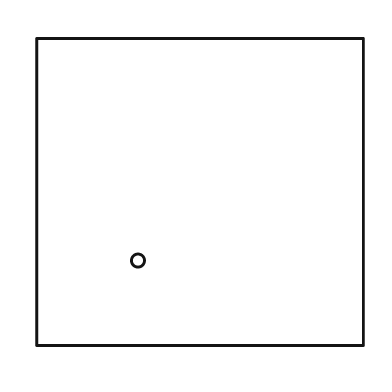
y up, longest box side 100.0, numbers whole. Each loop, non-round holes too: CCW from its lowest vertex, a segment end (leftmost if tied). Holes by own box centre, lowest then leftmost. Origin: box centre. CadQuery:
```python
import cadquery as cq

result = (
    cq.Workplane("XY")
    .moveTo(-50.0, -47.0)
    .lineTo(50.0, -47.0)
    .lineTo(50.0, 47.0)
    .lineTo(-50.0, 47.0)
    .close()
    .moveTo(-19.0, -21.0)
    .circle(2.0)
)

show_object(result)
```